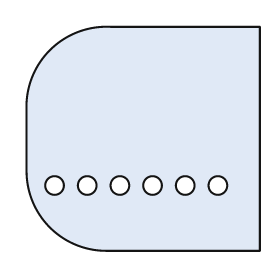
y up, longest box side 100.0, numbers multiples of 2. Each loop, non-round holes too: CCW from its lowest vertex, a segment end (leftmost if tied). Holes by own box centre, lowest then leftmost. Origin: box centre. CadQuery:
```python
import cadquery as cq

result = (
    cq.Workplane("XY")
    .moveTo(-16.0, -48.0)
    .lineTo(50.0, -48.0)
    .lineTo(50.0, 48.0)
    .lineTo(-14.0, 48.0)
    .threePointArc((-40.0, 38.0), (-50.0, 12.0))
    .lineTo(-50.0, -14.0)
    .threePointArc((-40.0, -38.0), (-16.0, -48.0))
    .close()
    .moveTo(-38.0, -20.0)
    .circle(4.0)
    .moveTo(-24.0, -20.0)
    .circle(4.0)
    .moveTo(-10.0, -20.0)
    .circle(4.0)
    .moveTo(4.0, -20.0)
    .circle(4.0)
    .moveTo(18.0, -20.0)
    .circle(4.0)
    .moveTo(32.0, -20.0)
    .circle(4.0)
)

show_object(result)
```